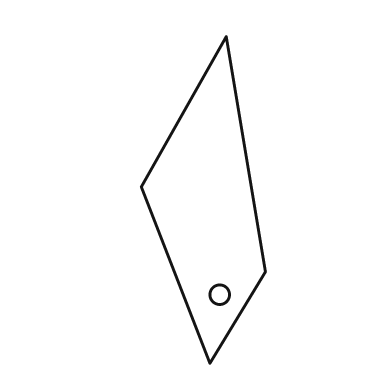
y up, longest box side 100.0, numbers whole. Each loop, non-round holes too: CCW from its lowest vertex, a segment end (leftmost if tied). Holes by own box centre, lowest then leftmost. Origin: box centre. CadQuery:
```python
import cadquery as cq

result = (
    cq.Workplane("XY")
    .moveTo(2.0, -50.0)
    .lineTo(19.0, -22.0)
    .lineTo(7.0, 50.0)
    .lineTo(-19.0, 4.0)
    .close()
    .moveTo(5.0, -29.0)
    .circle(3.0)
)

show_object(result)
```